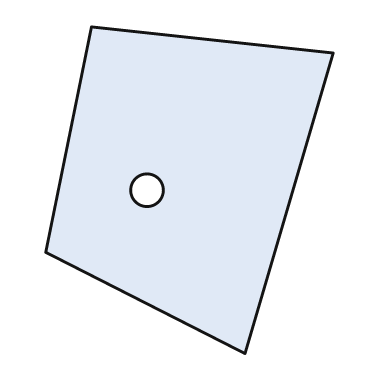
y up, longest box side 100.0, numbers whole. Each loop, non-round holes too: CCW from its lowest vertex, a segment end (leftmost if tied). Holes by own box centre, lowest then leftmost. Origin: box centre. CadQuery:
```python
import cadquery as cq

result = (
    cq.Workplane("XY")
    .moveTo(17.0, -50.0)
    .lineTo(44.0, 42.0)
    .lineTo(-30.0, 50.0)
    .lineTo(-44.0, -19.0)
    .close()
    .moveTo(-13.0, 0.0)
    .circle(5.0)
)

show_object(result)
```